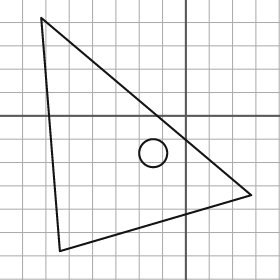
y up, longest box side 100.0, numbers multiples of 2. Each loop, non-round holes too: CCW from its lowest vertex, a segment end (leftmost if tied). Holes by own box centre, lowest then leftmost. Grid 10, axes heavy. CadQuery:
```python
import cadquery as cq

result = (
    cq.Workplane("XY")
    .moveTo(-54.0, -58.0)
    .lineTo(28.0, -34.0)
    .lineTo(-62.0, 42.0)
    .close()
    .moveTo(-14.0, -16.0)
    .circle(6.0)
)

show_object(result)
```